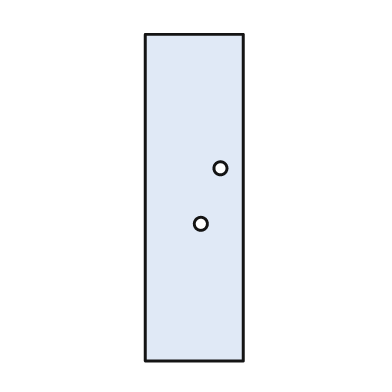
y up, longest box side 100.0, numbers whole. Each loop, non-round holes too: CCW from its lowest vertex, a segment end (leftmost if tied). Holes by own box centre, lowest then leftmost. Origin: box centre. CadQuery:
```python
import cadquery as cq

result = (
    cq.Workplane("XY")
    .moveTo(-15.0, -50.0)
    .lineTo(15.0, -50.0)
    .lineTo(15.0, 50.0)
    .lineTo(-15.0, 50.0)
    .close()
    .moveTo(2.0, -8.0)
    .circle(2.0)
    .moveTo(8.0, 9.0)
    .circle(2.0)
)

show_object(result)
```